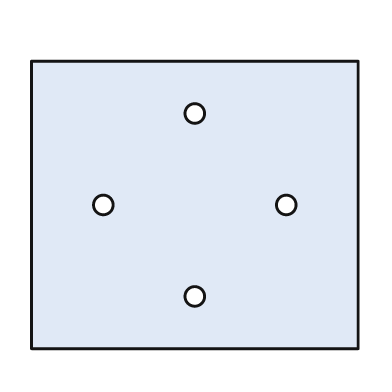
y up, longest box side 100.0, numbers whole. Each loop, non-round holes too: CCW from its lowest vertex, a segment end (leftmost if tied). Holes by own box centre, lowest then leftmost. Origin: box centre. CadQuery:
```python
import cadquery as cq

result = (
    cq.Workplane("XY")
    .moveTo(-50.0, -44.0)
    .lineTo(50.0, -44.0)
    .lineTo(50.0, 44.0)
    .lineTo(-50.0, 44.0)
    .close()
    .moveTo(0.0, -28.0)
    .circle(3.0)
    .moveTo(-28.0, 0.0)
    .circle(3.0)
    .moveTo(28.0, 0.0)
    .circle(3.0)
    .moveTo(0.0, 28.0)
    .circle(3.0)
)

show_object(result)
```